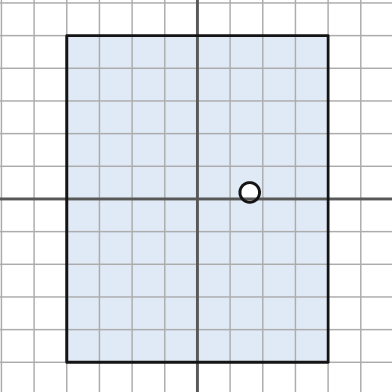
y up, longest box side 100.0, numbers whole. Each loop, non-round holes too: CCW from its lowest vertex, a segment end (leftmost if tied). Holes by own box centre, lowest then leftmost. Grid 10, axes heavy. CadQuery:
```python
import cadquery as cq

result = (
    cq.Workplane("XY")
    .moveTo(-40.0, -50.0)
    .lineTo(40.0, -50.0)
    .lineTo(40.0, 50.0)
    .lineTo(-40.0, 50.0)
    .close()
    .moveTo(16.0, 2.0)
    .circle(3.0)
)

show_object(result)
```